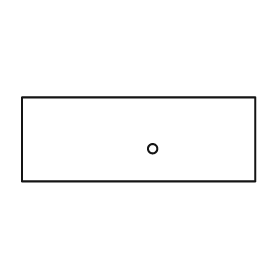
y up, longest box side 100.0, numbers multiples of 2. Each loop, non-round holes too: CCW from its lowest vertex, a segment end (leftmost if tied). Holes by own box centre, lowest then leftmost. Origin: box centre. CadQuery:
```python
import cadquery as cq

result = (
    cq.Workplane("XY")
    .moveTo(-50.0, -18.0)
    .lineTo(50.0, -18.0)
    .lineTo(50.0, 18.0)
    .lineTo(-50.0, 18.0)
    .close()
    .moveTo(6.0, -4.0)
    .circle(2.0)
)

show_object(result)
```